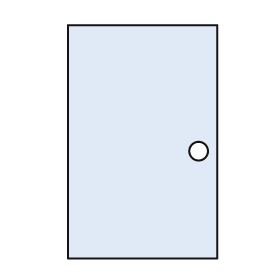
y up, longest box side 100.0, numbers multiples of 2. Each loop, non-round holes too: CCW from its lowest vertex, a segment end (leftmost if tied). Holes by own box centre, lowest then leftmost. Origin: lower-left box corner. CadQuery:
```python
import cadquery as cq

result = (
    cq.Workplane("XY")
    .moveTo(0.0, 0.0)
    .lineTo(64.0, 0.0)
    .lineTo(64.0, 100.0)
    .lineTo(0.0, 100.0)
    .close()
    .moveTo(56.0, 46.0)
    .circle(4.0)
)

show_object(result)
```